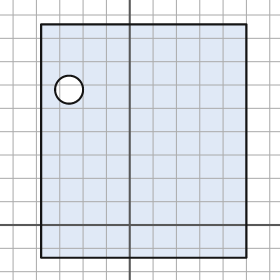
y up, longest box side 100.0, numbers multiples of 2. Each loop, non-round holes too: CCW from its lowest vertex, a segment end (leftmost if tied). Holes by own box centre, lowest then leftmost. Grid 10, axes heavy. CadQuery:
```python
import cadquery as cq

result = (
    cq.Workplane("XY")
    .moveTo(-38.0, -14.0)
    .lineTo(50.0, -14.0)
    .lineTo(50.0, 86.0)
    .lineTo(-38.0, 86.0)
    .close()
    .moveTo(-26.0, 58.0)
    .circle(6.0)
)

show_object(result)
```